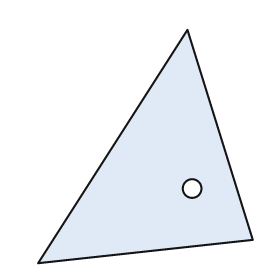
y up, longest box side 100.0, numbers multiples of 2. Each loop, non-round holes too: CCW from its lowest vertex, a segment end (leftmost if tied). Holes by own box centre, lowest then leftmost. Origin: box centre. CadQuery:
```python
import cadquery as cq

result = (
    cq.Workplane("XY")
    .moveTo(-46.0, -50.0)
    .lineTo(46.0, -40.0)
    .lineTo(18.0, 50.0)
    .close()
    .moveTo(20.0, -18.0)
    .circle(4.0)
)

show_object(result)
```